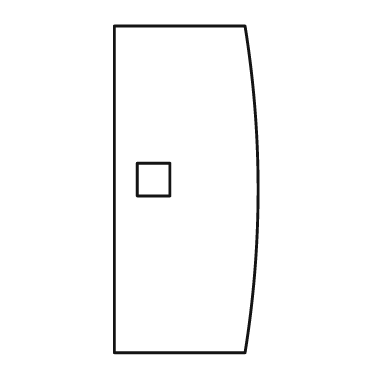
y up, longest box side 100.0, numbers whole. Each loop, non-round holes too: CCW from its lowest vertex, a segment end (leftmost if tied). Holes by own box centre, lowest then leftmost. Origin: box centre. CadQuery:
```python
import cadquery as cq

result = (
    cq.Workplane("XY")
    .moveTo(-22.0, -50.0)
    .lineTo(18.0, -50.0)
    .threePointArc((22.0, 0.0), (18.0, 50.0))
    .lineTo(-22.0, 50.0)
    .close()
    .moveTo(-15.0, -2.0)
    .lineTo(-5.0, -2.0)
    .lineTo(-5.0, 8.0)
    .lineTo(-15.0, 8.0)
    .close()
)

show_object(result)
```